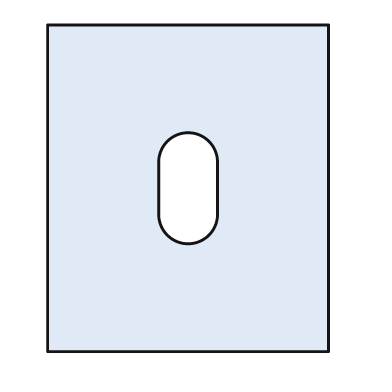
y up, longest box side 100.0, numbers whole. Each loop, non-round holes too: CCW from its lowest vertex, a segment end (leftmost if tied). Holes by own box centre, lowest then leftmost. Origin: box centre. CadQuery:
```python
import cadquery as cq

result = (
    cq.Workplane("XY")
    .moveTo(-43.0, -50.0)
    .lineTo(43.0, -50.0)
    .lineTo(43.0, 50.0)
    .lineTo(-43.0, 50.0)
    .close()
    .moveTo(-9.0, -8.0)
    .threePointArc((0.0, -17.0), (9.0, -8.0))
    .lineTo(9.0, 8.0)
    .threePointArc((0.0, 17.0), (-9.0, 8.0))
    .close()
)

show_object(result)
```